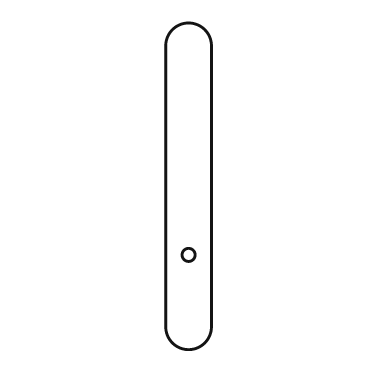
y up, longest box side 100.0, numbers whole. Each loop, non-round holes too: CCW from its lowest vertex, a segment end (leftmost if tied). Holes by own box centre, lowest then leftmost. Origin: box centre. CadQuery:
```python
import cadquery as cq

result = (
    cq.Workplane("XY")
    .moveTo(-7.0, -43.0)
    .threePointArc((0.0, -50.0), (7.0, -43.0))
    .lineTo(7.0, 43.0)
    .threePointArc((0.0, 50.0), (-7.0, 43.0))
    .close()
    .moveTo(0.0, -21.0)
    .circle(2.0)
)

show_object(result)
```